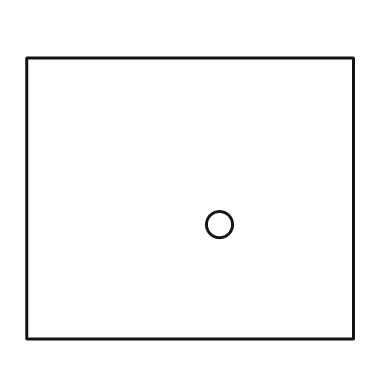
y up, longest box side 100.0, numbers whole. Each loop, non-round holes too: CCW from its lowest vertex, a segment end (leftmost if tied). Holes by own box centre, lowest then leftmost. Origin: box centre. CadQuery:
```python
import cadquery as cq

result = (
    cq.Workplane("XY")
    .moveTo(-50.0, -43.0)
    .lineTo(50.0, -43.0)
    .lineTo(50.0, 43.0)
    .lineTo(-50.0, 43.0)
    .close()
    .moveTo(9.0, -8.0)
    .circle(4.0)
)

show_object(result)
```